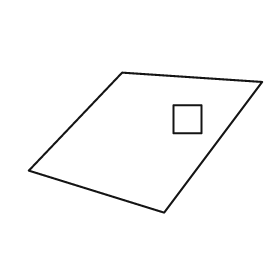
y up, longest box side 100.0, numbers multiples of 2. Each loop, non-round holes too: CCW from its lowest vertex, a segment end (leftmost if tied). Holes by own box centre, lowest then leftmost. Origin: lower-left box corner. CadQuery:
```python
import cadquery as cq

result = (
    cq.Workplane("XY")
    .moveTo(58.0, 0.0)
    .lineTo(100.0, 56.0)
    .lineTo(40.0, 60.0)
    .lineTo(0.0, 18.0)
    .close()
    .moveTo(62.0, 34.0)
    .lineTo(74.0, 34.0)
    .lineTo(74.0, 46.0)
    .lineTo(62.0, 46.0)
    .close()
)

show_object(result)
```